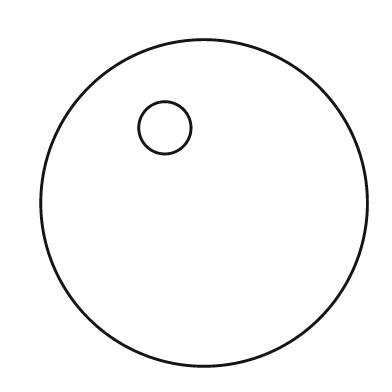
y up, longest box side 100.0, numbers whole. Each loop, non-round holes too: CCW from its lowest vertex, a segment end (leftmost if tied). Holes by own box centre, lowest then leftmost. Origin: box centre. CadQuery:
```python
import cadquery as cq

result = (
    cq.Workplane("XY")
    .moveTo(0.0, 0.0)
    .circle(50.0)
    .moveTo(-12.0, 23.0)
    .circle(8.0)
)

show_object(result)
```